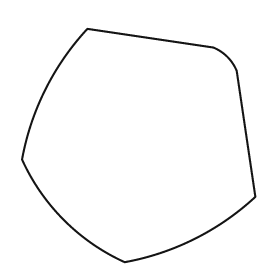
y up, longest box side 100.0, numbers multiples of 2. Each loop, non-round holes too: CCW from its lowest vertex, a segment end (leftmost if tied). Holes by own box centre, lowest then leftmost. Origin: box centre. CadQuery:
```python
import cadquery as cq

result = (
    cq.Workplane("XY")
    .moveTo(-6.0, -50.0)
    .threePointArc((24.0, -40.0), (50.0, -22.0))
    .lineTo(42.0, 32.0)
    .threePointArc((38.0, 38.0), (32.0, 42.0))
    .lineTo(-22.0, 50.0)
    .threePointArc((-40.0, 24.0), (-50.0, -6.0))
    .threePointArc((-32.0, -32.0), (-6.0, -50.0))
    .close()
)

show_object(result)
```